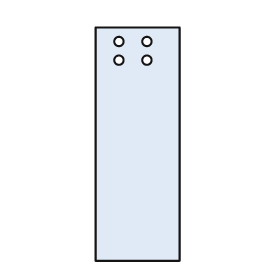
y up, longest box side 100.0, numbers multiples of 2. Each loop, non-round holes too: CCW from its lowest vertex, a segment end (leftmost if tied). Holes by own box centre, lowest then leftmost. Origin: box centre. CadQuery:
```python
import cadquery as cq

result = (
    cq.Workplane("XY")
    .moveTo(-18.0, -50.0)
    .lineTo(18.0, -50.0)
    .lineTo(18.0, 50.0)
    .lineTo(-18.0, 50.0)
    .close()
    .moveTo(-8.0, 36.0)
    .circle(2.0)
    .moveTo(4.0, 36.0)
    .circle(2.0)
    .moveTo(-8.0, 44.0)
    .circle(2.0)
    .moveTo(4.0, 44.0)
    .circle(2.0)
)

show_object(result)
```